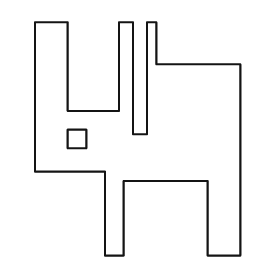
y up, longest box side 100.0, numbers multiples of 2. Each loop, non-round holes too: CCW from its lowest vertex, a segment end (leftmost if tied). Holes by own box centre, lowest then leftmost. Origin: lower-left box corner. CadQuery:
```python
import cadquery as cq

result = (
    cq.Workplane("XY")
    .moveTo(30.0, 0.0)
    .lineTo(38.0, 0.0)
    .lineTo(38.0, 32.0)
    .lineTo(74.0, 32.0)
    .lineTo(74.0, 0.0)
    .lineTo(88.0, 0.0)
    .lineTo(88.0, 82.0)
    .lineTo(52.0, 82.0)
    .lineTo(52.0, 100.0)
    .lineTo(48.0, 100.0)
    .lineTo(48.0, 52.0)
    .lineTo(42.0, 52.0)
    .lineTo(42.0, 100.0)
    .lineTo(36.0, 100.0)
    .lineTo(36.0, 62.0)
    .lineTo(14.0, 62.0)
    .lineTo(14.0, 100.0)
    .lineTo(0.0, 100.0)
    .lineTo(0.0, 36.0)
    .lineTo(30.0, 36.0)
    .close()
    .moveTo(14.0, 46.0)
    .lineTo(22.0, 46.0)
    .lineTo(22.0, 54.0)
    .lineTo(14.0, 54.0)
    .close()
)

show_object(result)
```